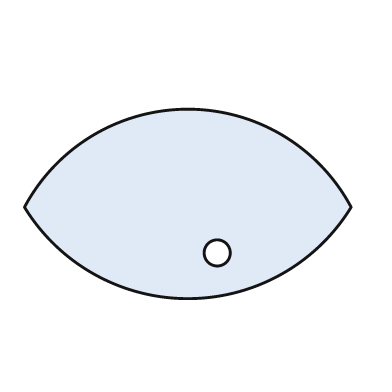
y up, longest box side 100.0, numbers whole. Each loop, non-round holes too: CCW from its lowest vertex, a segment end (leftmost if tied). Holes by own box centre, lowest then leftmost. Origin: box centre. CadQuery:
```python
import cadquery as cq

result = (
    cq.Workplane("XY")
    .moveTo(-50.0, -1.0)
    .threePointArc((0.0, -29.0), (50.0, -1.0))
    .threePointArc((0.0, 29.0), (-50.0, -1.0))
    .close()
    .moveTo(9.0, -15.0)
    .circle(4.0)
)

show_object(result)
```